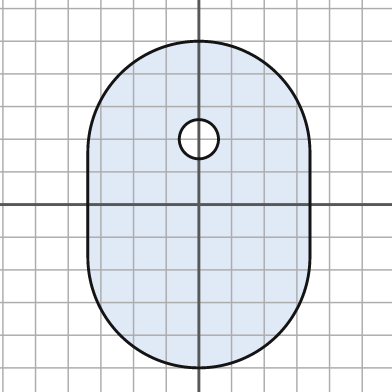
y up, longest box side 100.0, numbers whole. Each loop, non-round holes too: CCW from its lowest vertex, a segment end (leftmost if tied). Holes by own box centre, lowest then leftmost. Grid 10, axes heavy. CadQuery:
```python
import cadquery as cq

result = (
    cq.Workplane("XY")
    .moveTo(-34.0, -16.0)
    .threePointArc((0.0, -50.0), (34.0, -16.0))
    .lineTo(34.0, 16.0)
    .threePointArc((0.0, 50.0), (-34.0, 16.0))
    .close()
    .moveTo(0.0, 20.0)
    .circle(6.0)
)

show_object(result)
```